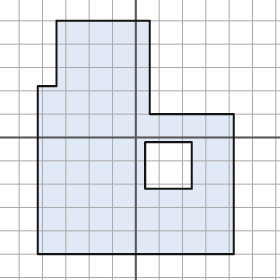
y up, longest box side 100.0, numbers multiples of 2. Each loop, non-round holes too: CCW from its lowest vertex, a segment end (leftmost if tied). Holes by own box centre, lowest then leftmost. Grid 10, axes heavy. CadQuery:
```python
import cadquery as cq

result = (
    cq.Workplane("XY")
    .moveTo(-42.0, -50.0)
    .lineTo(42.0, -50.0)
    .lineTo(42.0, 10.0)
    .lineTo(6.0, 10.0)
    .lineTo(6.0, 50.0)
    .lineTo(-34.0, 50.0)
    .lineTo(-34.0, 22.0)
    .lineTo(-42.0, 22.0)
    .close()
    .moveTo(4.0, -22.0)
    .lineTo(24.0, -22.0)
    .lineTo(24.0, -2.0)
    .lineTo(4.0, -2.0)
    .close()
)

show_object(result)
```